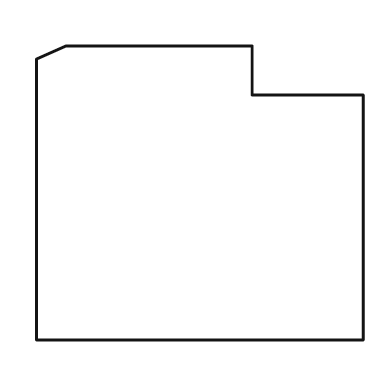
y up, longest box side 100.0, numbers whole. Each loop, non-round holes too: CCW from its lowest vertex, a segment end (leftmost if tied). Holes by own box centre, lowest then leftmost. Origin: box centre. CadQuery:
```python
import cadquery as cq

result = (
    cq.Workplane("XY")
    .moveTo(-50.0, -45.0)
    .lineTo(50.0, -45.0)
    .lineTo(50.0, 30.0)
    .lineTo(16.0, 30.0)
    .lineTo(16.0, 45.0)
    .lineTo(-41.0, 45.0)
    .lineTo(-50.0, 41.0)
    .close()
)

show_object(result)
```